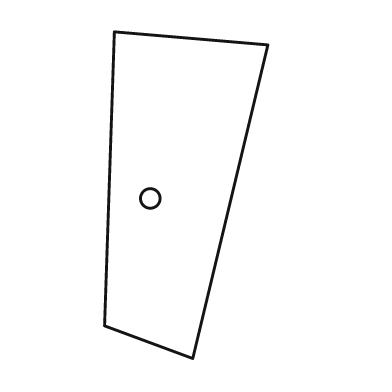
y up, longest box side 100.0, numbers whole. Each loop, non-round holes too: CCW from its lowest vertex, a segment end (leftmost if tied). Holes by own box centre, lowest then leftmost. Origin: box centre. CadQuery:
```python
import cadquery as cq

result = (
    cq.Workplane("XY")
    .moveTo(2.0, -50.0)
    .lineTo(25.0, 46.0)
    .lineTo(-22.0, 50.0)
    .lineTo(-25.0, -40.0)
    .close()
    .moveTo(-11.0, -1.0)
    .circle(3.0)
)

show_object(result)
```